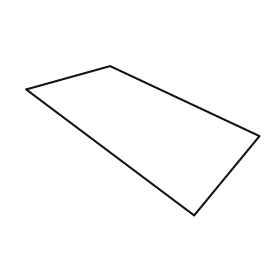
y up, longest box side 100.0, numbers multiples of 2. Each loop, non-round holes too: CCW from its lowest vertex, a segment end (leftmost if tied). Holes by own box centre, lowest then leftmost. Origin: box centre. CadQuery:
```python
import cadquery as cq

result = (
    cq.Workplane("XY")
    .moveTo(22.0, -32.0)
    .lineTo(50.0, 2.0)
    .lineTo(-14.0, 32.0)
    .lineTo(-50.0, 22.0)
    .close()
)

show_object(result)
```